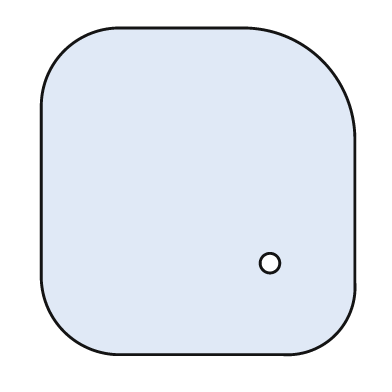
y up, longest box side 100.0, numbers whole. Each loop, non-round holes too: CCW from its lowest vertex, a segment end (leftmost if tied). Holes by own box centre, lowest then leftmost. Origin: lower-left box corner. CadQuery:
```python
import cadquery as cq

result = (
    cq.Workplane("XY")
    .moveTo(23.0, 0.0)
    .lineTo(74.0, 0.0)
    .threePointArc((90.0, 6.0), (96.0, 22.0))
    .lineTo(96.0, 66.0)
    .threePointArc((86.0, 90.0), (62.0, 100.0))
    .lineTo(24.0, 100.0)
    .threePointArc((7.0, 93.0), (0.0, 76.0))
    .lineTo(0.0, 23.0)
    .threePointArc((7.0, 7.0), (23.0, 0.0))
    .close()
    .moveTo(70.0, 28.0)
    .circle(3.0)
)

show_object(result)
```